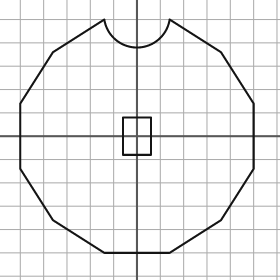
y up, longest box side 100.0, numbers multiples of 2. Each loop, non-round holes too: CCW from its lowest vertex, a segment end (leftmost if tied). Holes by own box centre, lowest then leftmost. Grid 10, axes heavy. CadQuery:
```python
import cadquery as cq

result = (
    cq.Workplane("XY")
    .moveTo(-14.0, -50.0)
    .lineTo(14.0, -50.0)
    .lineTo(36.0, -36.0)
    .lineTo(50.0, -14.0)
    .lineTo(50.0, 14.0)
    .lineTo(36.0, 36.0)
    .lineTo(14.0, 50.0)
    .threePointArc((0.0, 38.0), (-14.0, 50.0))
    .lineTo(-36.0, 36.0)
    .lineTo(-50.0, 14.0)
    .lineTo(-50.0, -14.0)
    .lineTo(-36.0, -36.0)
    .close()
    .moveTo(-6.0, -8.0)
    .lineTo(6.0, -8.0)
    .lineTo(6.0, 8.0)
    .lineTo(-6.0, 8.0)
    .close()
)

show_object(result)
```